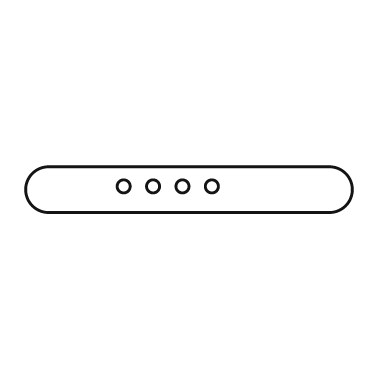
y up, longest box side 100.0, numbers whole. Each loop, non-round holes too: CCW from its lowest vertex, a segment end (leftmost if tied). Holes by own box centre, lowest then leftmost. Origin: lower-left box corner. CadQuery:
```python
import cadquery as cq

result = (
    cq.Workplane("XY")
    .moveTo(7.0, 0.0)
    .lineTo(93.0, 0.0)
    .threePointArc((100.0, 7.0), (93.0, 14.0))
    .lineTo(7.0, 14.0)
    .threePointArc((0.0, 7.0), (7.0, 0.0))
    .close()
    .moveTo(30.0, 8.0)
    .circle(2.0)
    .moveTo(39.0, 8.0)
    .circle(2.0)
    .moveTo(48.0, 8.0)
    .circle(2.0)
    .moveTo(57.0, 8.0)
    .circle(2.0)
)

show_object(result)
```